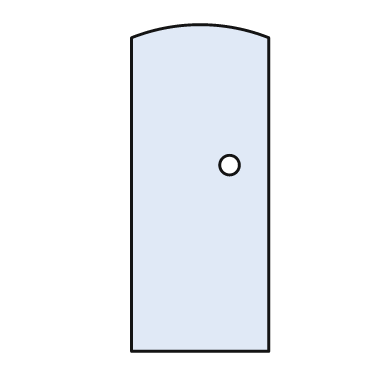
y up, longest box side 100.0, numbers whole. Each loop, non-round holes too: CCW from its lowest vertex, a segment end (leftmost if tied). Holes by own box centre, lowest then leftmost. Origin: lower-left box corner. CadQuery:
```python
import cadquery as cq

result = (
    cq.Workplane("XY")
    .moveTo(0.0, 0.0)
    .lineTo(42.0, 0.0)
    .lineTo(42.0, 96.0)
    .threePointArc((21.0, 100.0), (0.0, 96.0))
    .close()
    .moveTo(30.0, 57.0)
    .circle(3.0)
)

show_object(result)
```